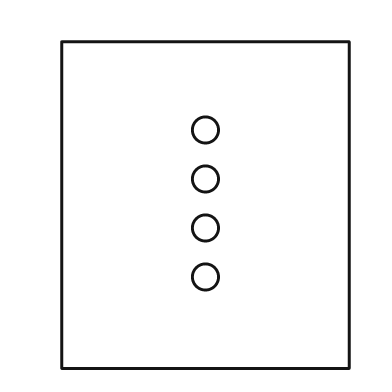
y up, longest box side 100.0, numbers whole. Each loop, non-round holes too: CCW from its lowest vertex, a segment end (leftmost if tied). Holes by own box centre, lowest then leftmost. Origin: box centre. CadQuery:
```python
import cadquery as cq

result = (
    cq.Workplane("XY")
    .moveTo(-44.0, -50.0)
    .lineTo(44.0, -50.0)
    .lineTo(44.0, 50.0)
    .lineTo(-44.0, 50.0)
    .close()
    .moveTo(0.0, -22.0)
    .circle(4.0)
    .moveTo(0.0, -7.0)
    .circle(4.0)
    .moveTo(0.0, 8.0)
    .circle(4.0)
    .moveTo(0.0, 23.0)
    .circle(4.0)
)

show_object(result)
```